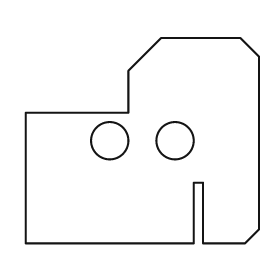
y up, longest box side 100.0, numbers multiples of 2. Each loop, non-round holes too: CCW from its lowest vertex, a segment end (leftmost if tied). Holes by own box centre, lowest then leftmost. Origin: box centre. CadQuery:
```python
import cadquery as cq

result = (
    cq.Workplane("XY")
    .moveTo(-50.0, -44.0)
    .lineTo(22.0, -44.0)
    .lineTo(22.0, -18.0)
    .lineTo(26.0, -18.0)
    .lineTo(26.0, -44.0)
    .lineTo(44.0, -44.0)
    .lineTo(50.0, -38.0)
    .lineTo(50.0, 36.0)
    .lineTo(42.0, 44.0)
    .lineTo(8.0, 44.0)
    .lineTo(-6.0, 30.0)
    .lineTo(-6.0, 12.0)
    .lineTo(-50.0, 12.0)
    .close()
    .moveTo(-14.0, 0.0)
    .circle(8.0)
    .moveTo(14.0, 0.0)
    .circle(8.0)
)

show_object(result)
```